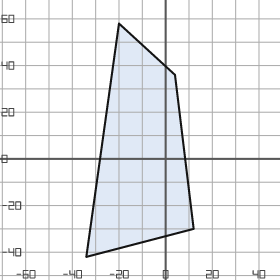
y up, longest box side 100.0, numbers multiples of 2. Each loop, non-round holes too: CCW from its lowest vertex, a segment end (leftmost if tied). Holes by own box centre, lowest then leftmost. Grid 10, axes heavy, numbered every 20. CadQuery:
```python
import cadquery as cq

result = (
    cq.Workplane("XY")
    .moveTo(-34.0, -42.0)
    .lineTo(12.0, -30.0)
    .lineTo(4.0, 36.0)
    .lineTo(-20.0, 58.0)
    .close()
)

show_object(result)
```